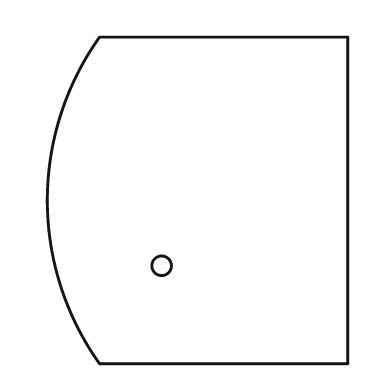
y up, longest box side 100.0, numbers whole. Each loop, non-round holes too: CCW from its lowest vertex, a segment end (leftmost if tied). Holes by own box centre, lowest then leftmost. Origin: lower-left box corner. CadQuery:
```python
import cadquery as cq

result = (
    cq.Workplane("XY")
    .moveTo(16.0, 0.0)
    .lineTo(92.0, 0.0)
    .lineTo(92.0, 100.0)
    .lineTo(16.0, 100.0)
    .threePointArc((0.0, 50.0), (16.0, 0.0))
    .close()
    .moveTo(35.0, 30.0)
    .circle(3.0)
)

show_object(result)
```